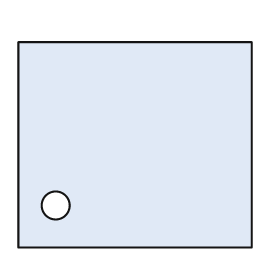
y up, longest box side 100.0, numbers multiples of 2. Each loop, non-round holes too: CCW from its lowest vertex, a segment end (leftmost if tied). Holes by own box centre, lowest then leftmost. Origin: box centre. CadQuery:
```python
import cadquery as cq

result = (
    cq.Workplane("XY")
    .moveTo(-50.0, -44.0)
    .lineTo(50.0, -44.0)
    .lineTo(50.0, 44.0)
    .lineTo(-50.0, 44.0)
    .close()
    .moveTo(-34.0, -26.0)
    .circle(6.0)
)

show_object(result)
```